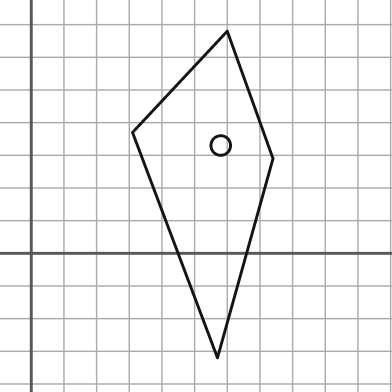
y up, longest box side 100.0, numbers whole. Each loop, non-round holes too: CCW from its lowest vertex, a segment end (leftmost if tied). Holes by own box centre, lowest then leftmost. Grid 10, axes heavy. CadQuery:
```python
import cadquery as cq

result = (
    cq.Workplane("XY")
    .moveTo(57.0, -32.0)
    .lineTo(74.0, 29.0)
    .lineTo(60.0, 68.0)
    .lineTo(31.0, 37.0)
    .close()
    .moveTo(58.0, 33.0)
    .circle(3.0)
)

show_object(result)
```